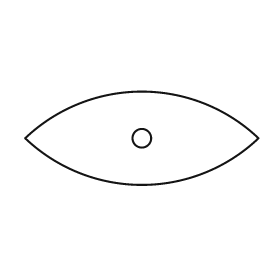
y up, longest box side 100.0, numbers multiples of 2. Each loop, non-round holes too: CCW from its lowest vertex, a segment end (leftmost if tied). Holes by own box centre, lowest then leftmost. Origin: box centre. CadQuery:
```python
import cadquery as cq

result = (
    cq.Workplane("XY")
    .moveTo(-50.0, 0.0)
    .threePointArc((0.0, -20.0), (50.0, 0.0))
    .threePointArc((0.0, 20.0), (-50.0, 0.0))
    .close()
    .moveTo(0.0, 0.0)
    .circle(4.0)
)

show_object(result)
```